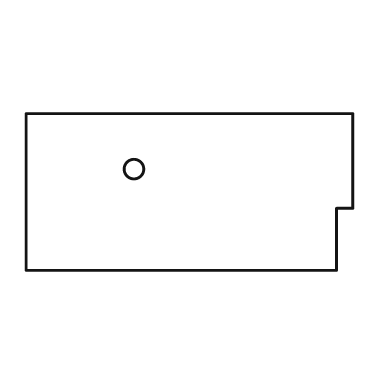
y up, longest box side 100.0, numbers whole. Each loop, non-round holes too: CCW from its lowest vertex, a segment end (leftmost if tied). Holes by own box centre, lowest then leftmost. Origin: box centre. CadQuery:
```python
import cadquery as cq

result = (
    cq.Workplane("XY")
    .moveTo(-50.0, -24.0)
    .lineTo(45.0, -24.0)
    .lineTo(45.0, -5.0)
    .lineTo(50.0, -5.0)
    .lineTo(50.0, 24.0)
    .lineTo(-50.0, 24.0)
    .close()
    .moveTo(-17.0, 7.0)
    .circle(3.0)
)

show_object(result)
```